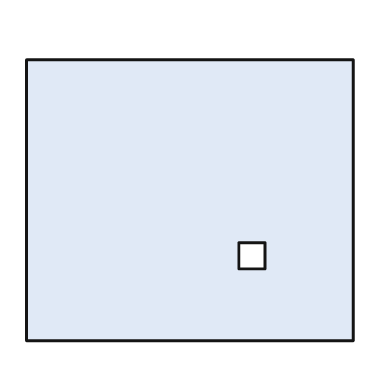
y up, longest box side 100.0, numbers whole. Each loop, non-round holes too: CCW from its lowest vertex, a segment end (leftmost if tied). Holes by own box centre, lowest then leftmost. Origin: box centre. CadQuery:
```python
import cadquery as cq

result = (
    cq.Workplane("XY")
    .moveTo(-50.0, -43.0)
    .lineTo(50.0, -43.0)
    .lineTo(50.0, 43.0)
    .lineTo(-50.0, 43.0)
    .close()
    .moveTo(15.0, -21.0)
    .lineTo(23.0, -21.0)
    .lineTo(23.0, -13.0)
    .lineTo(15.0, -13.0)
    .close()
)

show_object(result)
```